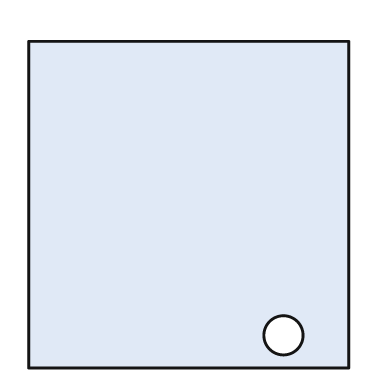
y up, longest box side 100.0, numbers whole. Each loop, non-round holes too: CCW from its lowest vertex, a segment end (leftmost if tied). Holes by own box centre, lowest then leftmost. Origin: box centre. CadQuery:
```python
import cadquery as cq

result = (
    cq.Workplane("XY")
    .moveTo(-49.0, -50.0)
    .lineTo(49.0, -50.0)
    .lineTo(49.0, 50.0)
    .lineTo(-49.0, 50.0)
    .close()
    .moveTo(29.0, -40.0)
    .circle(6.0)
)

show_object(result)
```